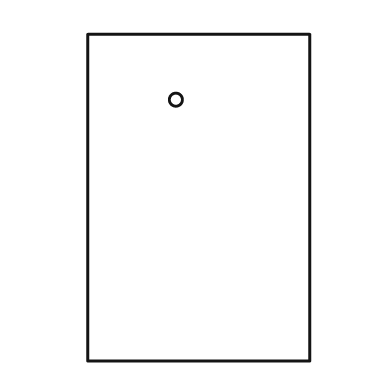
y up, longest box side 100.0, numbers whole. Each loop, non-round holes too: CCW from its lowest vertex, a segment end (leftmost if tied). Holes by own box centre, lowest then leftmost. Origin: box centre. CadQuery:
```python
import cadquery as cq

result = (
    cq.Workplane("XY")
    .moveTo(-34.0, -50.0)
    .lineTo(34.0, -50.0)
    .lineTo(34.0, 50.0)
    .lineTo(-34.0, 50.0)
    .close()
    .moveTo(-7.0, 30.0)
    .circle(2.0)
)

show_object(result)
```